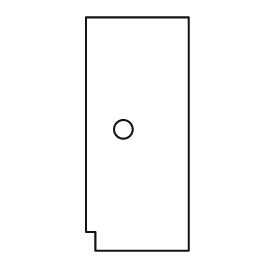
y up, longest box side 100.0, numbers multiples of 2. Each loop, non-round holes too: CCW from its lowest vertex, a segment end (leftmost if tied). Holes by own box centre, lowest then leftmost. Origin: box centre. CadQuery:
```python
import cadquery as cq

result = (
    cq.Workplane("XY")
    .moveTo(-18.0, -50.0)
    .lineTo(22.0, -50.0)
    .lineTo(22.0, 50.0)
    .lineTo(-22.0, 50.0)
    .lineTo(-22.0, -42.0)
    .lineTo(-18.0, -42.0)
    .close()
    .moveTo(-6.0, 2.0)
    .circle(4.0)
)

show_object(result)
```